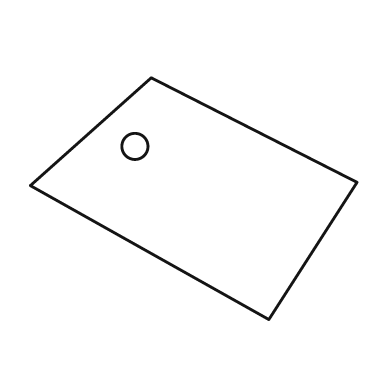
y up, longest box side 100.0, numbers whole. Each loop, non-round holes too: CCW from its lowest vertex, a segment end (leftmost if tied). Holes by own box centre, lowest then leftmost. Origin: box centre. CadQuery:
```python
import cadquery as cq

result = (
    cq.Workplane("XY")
    .moveTo(23.0, -37.0)
    .lineTo(50.0, 5.0)
    .lineTo(-13.0, 37.0)
    .lineTo(-50.0, 4.0)
    .close()
    .moveTo(-18.0, 16.0)
    .circle(4.0)
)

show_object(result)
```